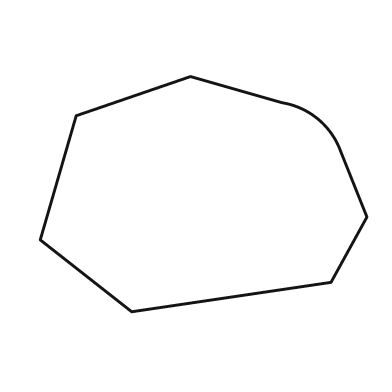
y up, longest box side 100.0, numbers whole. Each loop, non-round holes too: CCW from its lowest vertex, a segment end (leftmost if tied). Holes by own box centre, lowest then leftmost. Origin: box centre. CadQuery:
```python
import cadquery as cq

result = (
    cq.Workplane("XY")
    .moveTo(-22.0, -36.0)
    .lineTo(39.0, -27.0)
    .lineTo(50.0, -7.0)
    .lineTo(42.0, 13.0)
    .threePointArc((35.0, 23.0), (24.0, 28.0))
    .lineTo(-4.0, 36.0)
    .lineTo(-39.0, 24.0)
    .lineTo(-50.0, -14.0)
    .close()
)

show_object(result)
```